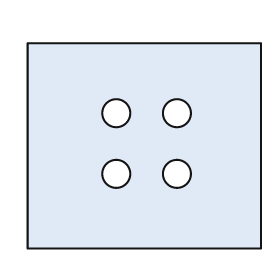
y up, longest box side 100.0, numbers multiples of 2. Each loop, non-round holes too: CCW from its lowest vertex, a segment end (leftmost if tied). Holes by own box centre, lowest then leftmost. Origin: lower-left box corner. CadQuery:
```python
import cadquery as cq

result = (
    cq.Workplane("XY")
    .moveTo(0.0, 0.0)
    .lineTo(100.0, 0.0)
    .lineTo(100.0, 88.0)
    .lineTo(0.0, 88.0)
    .close()
    .moveTo(38.0, 32.0)
    .circle(6.0)
    .moveTo(64.0, 32.0)
    .circle(6.0)
    .moveTo(38.0, 58.0)
    .circle(6.0)
    .moveTo(64.0, 58.0)
    .circle(6.0)
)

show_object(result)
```